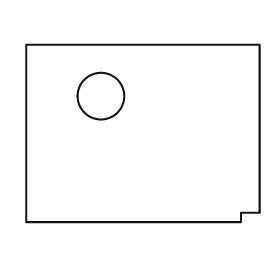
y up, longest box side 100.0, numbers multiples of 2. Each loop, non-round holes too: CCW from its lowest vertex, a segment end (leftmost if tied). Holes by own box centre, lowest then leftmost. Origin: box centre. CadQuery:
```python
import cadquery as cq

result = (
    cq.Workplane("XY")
    .moveTo(-50.0, -38.0)
    .lineTo(42.0, -38.0)
    .lineTo(42.0, -34.0)
    .lineTo(50.0, -34.0)
    .lineTo(50.0, 38.0)
    .lineTo(-50.0, 38.0)
    .close()
    .moveTo(-18.0, 16.0)
    .circle(10.0)
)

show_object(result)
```